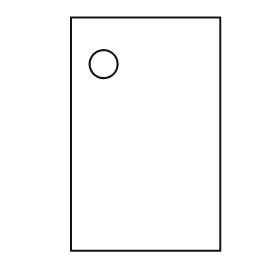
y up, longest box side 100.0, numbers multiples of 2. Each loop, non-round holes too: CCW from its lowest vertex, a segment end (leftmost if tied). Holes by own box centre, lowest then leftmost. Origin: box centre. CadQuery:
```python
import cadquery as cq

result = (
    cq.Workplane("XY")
    .moveTo(-32.0, -50.0)
    .lineTo(32.0, -50.0)
    .lineTo(32.0, 50.0)
    .lineTo(-32.0, 50.0)
    .close()
    .moveTo(-18.0, 30.0)
    .circle(6.0)
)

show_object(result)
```